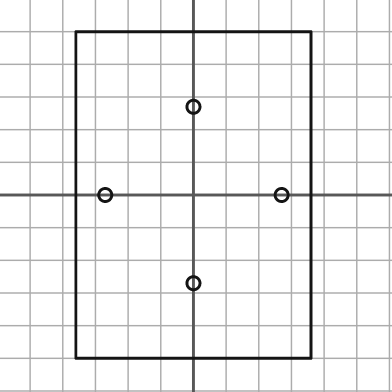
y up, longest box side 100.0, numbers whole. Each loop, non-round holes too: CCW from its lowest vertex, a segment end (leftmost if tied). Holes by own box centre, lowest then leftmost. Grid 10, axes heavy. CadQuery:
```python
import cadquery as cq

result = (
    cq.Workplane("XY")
    .moveTo(-36.0, -50.0)
    .lineTo(36.0, -50.0)
    .lineTo(36.0, 50.0)
    .lineTo(-36.0, 50.0)
    .close()
    .moveTo(0.0, -27.0)
    .circle(2.0)
    .moveTo(-27.0, 0.0)
    .circle(2.0)
    .moveTo(27.0, 0.0)
    .circle(2.0)
    .moveTo(0.0, 27.0)
    .circle(2.0)
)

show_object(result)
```